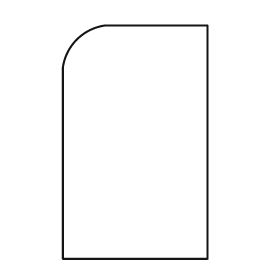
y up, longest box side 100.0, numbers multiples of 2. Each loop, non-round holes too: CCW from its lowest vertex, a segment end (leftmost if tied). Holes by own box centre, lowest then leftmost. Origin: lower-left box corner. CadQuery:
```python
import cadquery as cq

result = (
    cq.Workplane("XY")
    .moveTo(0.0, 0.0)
    .lineTo(62.0, 0.0)
    .lineTo(62.0, 100.0)
    .lineTo(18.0, 100.0)
    .threePointArc((6.0, 94.0), (0.0, 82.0))
    .close()
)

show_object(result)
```